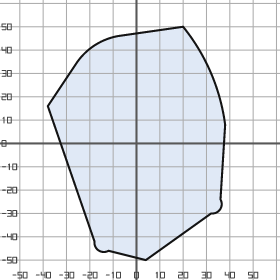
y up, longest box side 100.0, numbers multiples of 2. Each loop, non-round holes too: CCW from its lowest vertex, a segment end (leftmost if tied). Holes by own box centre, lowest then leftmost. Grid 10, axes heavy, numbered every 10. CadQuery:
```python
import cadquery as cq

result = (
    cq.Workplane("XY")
    .moveTo(4.0, -50.0)
    .lineTo(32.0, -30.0)
    .threePointArc((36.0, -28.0), (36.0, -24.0))
    .lineTo(38.0, 8.0)
    .threePointArc((32.0, 30.0), (20.0, 50.0))
    .lineTo(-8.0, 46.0)
    .threePointArc((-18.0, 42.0), (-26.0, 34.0))
    .lineTo(-38.0, 16.0)
    .lineTo(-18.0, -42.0)
    .threePointArc((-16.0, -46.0), (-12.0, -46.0))
    .close()
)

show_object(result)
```